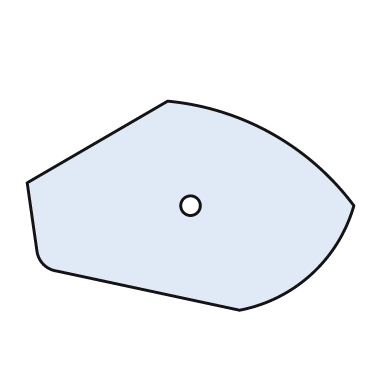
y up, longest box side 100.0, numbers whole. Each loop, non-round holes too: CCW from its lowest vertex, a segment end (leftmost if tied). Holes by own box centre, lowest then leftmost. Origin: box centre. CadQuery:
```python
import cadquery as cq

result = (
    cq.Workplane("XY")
    .moveTo(15.0, -32.0)
    .threePointArc((37.0, -21.0), (50.0, 0.0))
    .threePointArc((25.0, 22.0), (-7.0, 32.0))
    .lineTo(-50.0, 7.0)
    .lineTo(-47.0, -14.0)
    .threePointArc((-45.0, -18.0), (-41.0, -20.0))
    .close()
    .moveTo(0.0, 0.0)
    .circle(3.0)
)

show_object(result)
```